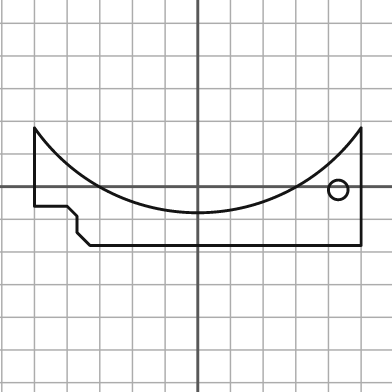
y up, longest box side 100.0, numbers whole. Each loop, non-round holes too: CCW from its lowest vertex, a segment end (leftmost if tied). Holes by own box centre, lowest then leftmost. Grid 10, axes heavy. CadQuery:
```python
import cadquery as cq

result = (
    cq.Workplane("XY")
    .moveTo(-33.0, -18.0)
    .lineTo(50.0, -18.0)
    .lineTo(50.0, 18.0)
    .threePointArc((0.0, -8.0), (-50.0, 18.0))
    .lineTo(-50.0, -6.0)
    .lineTo(-40.0, -6.0)
    .lineTo(-37.0, -9.0)
    .lineTo(-37.0, -14.0)
    .close()
    .moveTo(43.0, -1.0)
    .circle(3.0)
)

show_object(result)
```